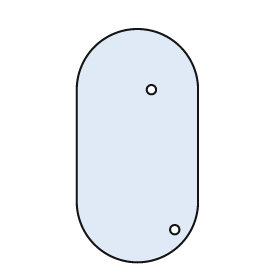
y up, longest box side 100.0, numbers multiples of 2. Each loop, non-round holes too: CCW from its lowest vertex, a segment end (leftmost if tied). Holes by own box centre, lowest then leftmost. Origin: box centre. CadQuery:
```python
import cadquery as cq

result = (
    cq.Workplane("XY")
    .moveTo(-26.0, -24.0)
    .threePointArc((0.0, -50.0), (26.0, -24.0))
    .lineTo(26.0, 24.0)
    .threePointArc((0.0, 50.0), (-26.0, 24.0))
    .close()
    .moveTo(16.0, -36.0)
    .circle(2.0)
    .moveTo(6.0, 24.0)
    .circle(2.0)
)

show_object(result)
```